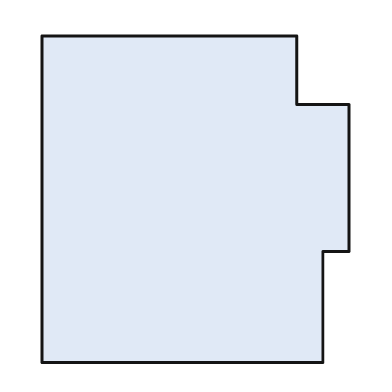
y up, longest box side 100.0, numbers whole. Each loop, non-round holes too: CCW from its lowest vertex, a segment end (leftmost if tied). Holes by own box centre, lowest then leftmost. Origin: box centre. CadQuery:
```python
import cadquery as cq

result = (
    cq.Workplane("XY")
    .moveTo(-47.0, -50.0)
    .lineTo(39.0, -50.0)
    .lineTo(39.0, -16.0)
    .lineTo(47.0, -16.0)
    .lineTo(47.0, 29.0)
    .lineTo(31.0, 29.0)
    .lineTo(31.0, 50.0)
    .lineTo(-47.0, 50.0)
    .close()
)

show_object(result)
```